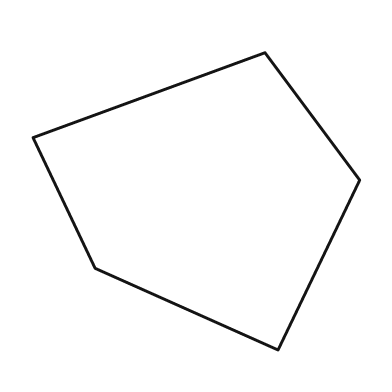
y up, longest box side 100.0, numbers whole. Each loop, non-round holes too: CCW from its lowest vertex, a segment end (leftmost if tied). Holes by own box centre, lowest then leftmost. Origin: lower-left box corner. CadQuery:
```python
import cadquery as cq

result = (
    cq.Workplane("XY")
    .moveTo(75.0, 0.0)
    .lineTo(100.0, 52.0)
    .lineTo(71.0, 91.0)
    .lineTo(0.0, 65.0)
    .lineTo(19.0, 25.0)
    .close()
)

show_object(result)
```